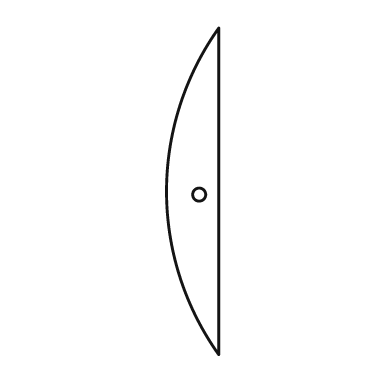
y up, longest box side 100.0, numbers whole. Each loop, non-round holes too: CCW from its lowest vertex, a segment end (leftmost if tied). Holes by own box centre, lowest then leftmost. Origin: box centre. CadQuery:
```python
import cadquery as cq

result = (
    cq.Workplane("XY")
    .moveTo(8.0, -50.0)
    .lineTo(8.0, 50.0)
    .threePointArc((-8.0, 0.0), (8.0, -50.0))
    .close()
    .moveTo(2.0, -1.0)
    .circle(2.0)
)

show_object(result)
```